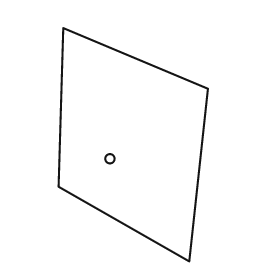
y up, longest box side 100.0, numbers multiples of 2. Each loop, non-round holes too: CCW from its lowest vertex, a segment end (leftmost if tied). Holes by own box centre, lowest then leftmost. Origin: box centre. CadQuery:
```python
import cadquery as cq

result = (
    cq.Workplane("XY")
    .moveTo(24.0, -50.0)
    .lineTo(32.0, 24.0)
    .lineTo(-30.0, 50.0)
    .lineTo(-32.0, -18.0)
    .close()
    .moveTo(-10.0, -6.0)
    .circle(2.0)
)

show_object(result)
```